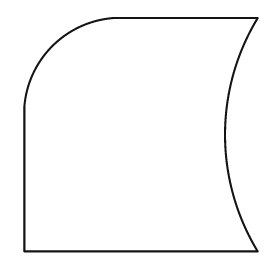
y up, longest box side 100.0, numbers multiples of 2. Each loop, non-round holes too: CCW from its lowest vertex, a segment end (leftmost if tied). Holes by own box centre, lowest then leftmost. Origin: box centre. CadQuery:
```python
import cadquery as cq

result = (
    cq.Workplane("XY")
    .moveTo(-50.0, -50.0)
    .lineTo(50.0, -50.0)
    .threePointArc((36.0, 0.0), (50.0, 50.0))
    .lineTo(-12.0, 50.0)
    .threePointArc((-38.0, 38.0), (-50.0, 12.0))
    .close()
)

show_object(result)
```